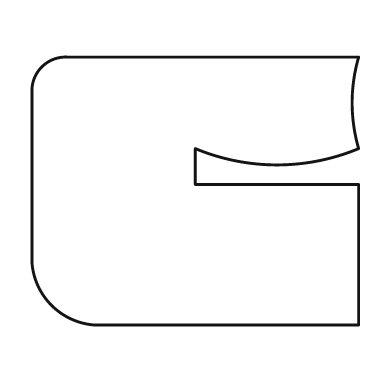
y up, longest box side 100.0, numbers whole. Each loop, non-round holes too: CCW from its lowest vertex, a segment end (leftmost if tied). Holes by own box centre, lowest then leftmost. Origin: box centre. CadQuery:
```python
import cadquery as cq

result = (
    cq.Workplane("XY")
    .moveTo(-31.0, -41.0)
    .lineTo(50.0, -41.0)
    .lineTo(50.0, 2.0)
    .lineTo(0.0, 2.0)
    .lineTo(0.0, 13.0)
    .threePointArc((25.0, 8.0), (50.0, 13.0))
    .threePointArc((48.0, 27.0), (50.0, 41.0))
    .lineTo(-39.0, 41.0)
    .threePointArc((-47.0, 38.0), (-50.0, 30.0))
    .lineTo(-50.0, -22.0)
    .threePointArc((-44.0, -35.0), (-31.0, -41.0))
    .close()
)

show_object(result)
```